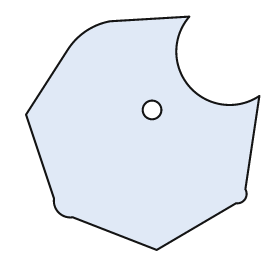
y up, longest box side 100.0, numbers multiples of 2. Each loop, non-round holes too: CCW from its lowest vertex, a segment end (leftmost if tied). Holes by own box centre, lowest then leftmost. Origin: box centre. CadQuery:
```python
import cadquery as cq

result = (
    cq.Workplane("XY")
    .moveTo(6.0, -50.0)
    .lineTo(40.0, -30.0)
    .threePointArc((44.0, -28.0), (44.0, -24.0))
    .lineTo(50.0, 16.0)
    .threePointArc((20.0, 20.0), (20.0, 50.0))
    .lineTo(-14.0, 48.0)
    .threePointArc((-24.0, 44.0), (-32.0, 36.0))
    .lineTo(-50.0, 8.0)
    .lineTo(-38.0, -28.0)
    .threePointArc((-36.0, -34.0), (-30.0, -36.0))
    .close()
    .moveTo(4.0, 10.0)
    .circle(4.0)
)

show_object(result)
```